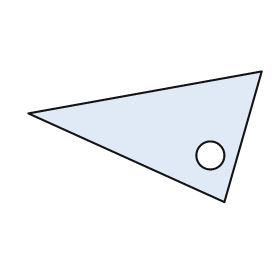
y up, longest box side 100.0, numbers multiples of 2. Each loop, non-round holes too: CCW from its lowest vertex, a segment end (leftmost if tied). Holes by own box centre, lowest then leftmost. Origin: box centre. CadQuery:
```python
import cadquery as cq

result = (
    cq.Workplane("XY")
    .moveTo(34.0, -28.0)
    .lineTo(50.0, 28.0)
    .lineTo(-50.0, 10.0)
    .close()
    .moveTo(28.0, -8.0)
    .circle(6.0)
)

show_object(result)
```